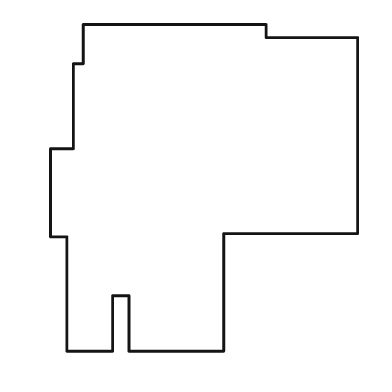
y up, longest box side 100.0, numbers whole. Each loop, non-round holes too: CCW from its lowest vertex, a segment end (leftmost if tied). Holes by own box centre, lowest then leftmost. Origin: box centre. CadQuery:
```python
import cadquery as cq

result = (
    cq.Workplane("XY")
    .moveTo(-42.0, -50.0)
    .lineTo(-28.0, -50.0)
    .lineTo(-28.0, -33.0)
    .lineTo(-23.0, -33.0)
    .lineTo(-23.0, -50.0)
    .lineTo(6.0, -50.0)
    .lineTo(6.0, -14.0)
    .lineTo(47.0, -14.0)
    .lineTo(47.0, 46.0)
    .lineTo(19.0, 46.0)
    .lineTo(19.0, 50.0)
    .lineTo(-37.0, 50.0)
    .lineTo(-37.0, 38.0)
    .lineTo(-40.0, 38.0)
    .lineTo(-40.0, 12.0)
    .lineTo(-47.0, 12.0)
    .lineTo(-47.0, -15.0)
    .lineTo(-42.0, -15.0)
    .close()
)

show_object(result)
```